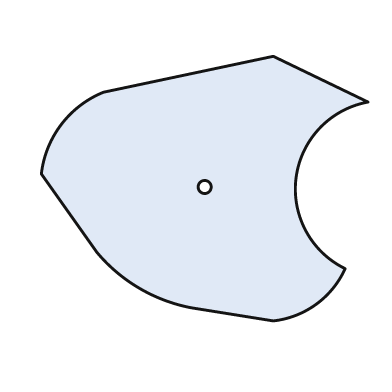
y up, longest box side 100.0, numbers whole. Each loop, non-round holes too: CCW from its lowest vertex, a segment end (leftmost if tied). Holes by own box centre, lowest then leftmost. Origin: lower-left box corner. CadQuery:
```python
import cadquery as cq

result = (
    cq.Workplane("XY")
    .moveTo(71.0, 0.0)
    .threePointArc((84.0, 5.0), (93.0, 16.0))
    .threePointArc((78.0, 44.0), (100.0, 67.0))
    .lineTo(71.0, 81.0)
    .lineTo(19.0, 70.0)
    .threePointArc((6.0, 60.0), (0.0, 45.0))
    .lineTo(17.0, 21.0)
    .threePointArc((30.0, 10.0), (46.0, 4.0))
    .close()
    .moveTo(50.0, 41.0)
    .circle(2.0)
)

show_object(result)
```